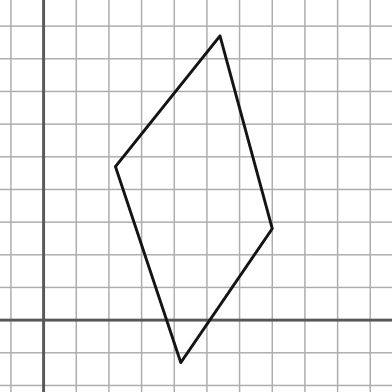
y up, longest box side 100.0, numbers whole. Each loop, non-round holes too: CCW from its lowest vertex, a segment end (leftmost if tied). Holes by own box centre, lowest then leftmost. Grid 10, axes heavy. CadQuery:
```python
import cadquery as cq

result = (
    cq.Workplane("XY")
    .moveTo(42.0, -13.0)
    .lineTo(70.0, 28.0)
    .lineTo(54.0, 87.0)
    .lineTo(22.0, 47.0)
    .close()
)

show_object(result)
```